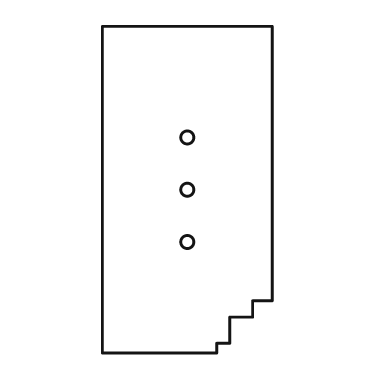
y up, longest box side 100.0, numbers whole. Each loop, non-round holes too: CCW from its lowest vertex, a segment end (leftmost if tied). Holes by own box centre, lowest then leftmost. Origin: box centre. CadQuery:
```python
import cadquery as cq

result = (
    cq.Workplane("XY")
    .moveTo(-26.0, -50.0)
    .lineTo(9.0, -50.0)
    .lineTo(9.0, -47.0)
    .lineTo(13.0, -47.0)
    .lineTo(13.0, -39.0)
    .lineTo(20.0, -39.0)
    .lineTo(20.0, -34.0)
    .lineTo(26.0, -34.0)
    .lineTo(26.0, 50.0)
    .lineTo(-26.0, 50.0)
    .close()
    .moveTo(0.0, -16.0)
    .circle(2.0)
    .moveTo(0.0, 0.0)
    .circle(2.0)
    .moveTo(0.0, 16.0)
    .circle(2.0)
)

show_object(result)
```